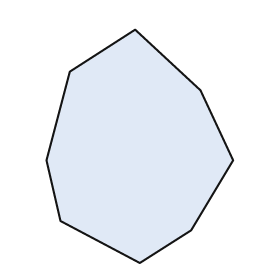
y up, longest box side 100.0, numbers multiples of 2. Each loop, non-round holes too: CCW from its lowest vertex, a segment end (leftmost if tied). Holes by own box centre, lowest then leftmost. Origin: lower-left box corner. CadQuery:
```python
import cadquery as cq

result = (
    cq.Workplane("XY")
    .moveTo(40.0, 0.0)
    .lineTo(62.0, 14.0)
    .lineTo(80.0, 44.0)
    .lineTo(66.0, 74.0)
    .lineTo(38.0, 100.0)
    .lineTo(10.0, 82.0)
    .lineTo(0.0, 44.0)
    .lineTo(6.0, 18.0)
    .close()
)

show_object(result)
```